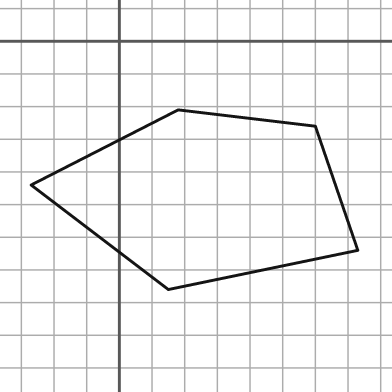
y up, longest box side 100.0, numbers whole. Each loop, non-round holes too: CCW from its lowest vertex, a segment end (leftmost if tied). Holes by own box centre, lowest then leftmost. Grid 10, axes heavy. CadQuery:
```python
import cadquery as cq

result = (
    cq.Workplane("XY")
    .moveTo(15.0, -76.0)
    .lineTo(73.0, -64.0)
    .lineTo(60.0, -26.0)
    .lineTo(18.0, -21.0)
    .lineTo(-27.0, -44.0)
    .close()
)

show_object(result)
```